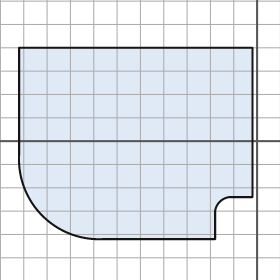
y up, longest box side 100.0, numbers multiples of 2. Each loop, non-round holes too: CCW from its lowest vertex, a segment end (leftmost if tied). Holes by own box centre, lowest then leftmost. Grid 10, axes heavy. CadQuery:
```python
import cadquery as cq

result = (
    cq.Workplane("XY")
    .moveTo(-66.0, -42.0)
    .lineTo(-18.0, -42.0)
    .lineTo(-18.0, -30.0)
    .threePointArc((-16.0, -26.0), (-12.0, -24.0))
    .lineTo(-2.0, -24.0)
    .lineTo(-2.0, 40.0)
    .lineTo(-102.0, 40.0)
    .lineTo(-102.0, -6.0)
    .threePointArc((-92.0, -32.0), (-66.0, -42.0))
    .close()
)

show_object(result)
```